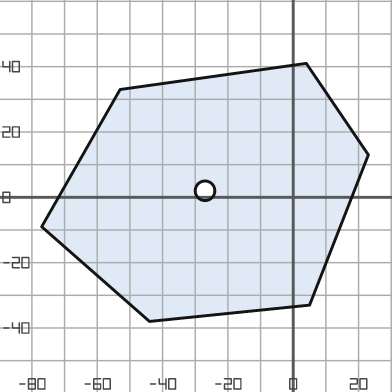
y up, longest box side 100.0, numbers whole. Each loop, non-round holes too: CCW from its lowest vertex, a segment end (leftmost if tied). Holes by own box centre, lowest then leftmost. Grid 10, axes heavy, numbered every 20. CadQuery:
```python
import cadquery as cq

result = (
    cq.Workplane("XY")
    .moveTo(-44.0, -38.0)
    .lineTo(5.0, -33.0)
    .lineTo(23.0, 13.0)
    .lineTo(4.0, 41.0)
    .lineTo(-53.0, 33.0)
    .lineTo(-77.0, -9.0)
    .close()
    .moveTo(-27.0, 2.0)
    .circle(3.0)
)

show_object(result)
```